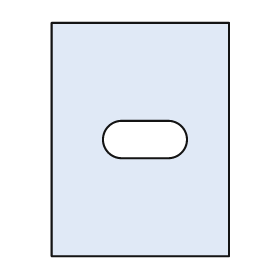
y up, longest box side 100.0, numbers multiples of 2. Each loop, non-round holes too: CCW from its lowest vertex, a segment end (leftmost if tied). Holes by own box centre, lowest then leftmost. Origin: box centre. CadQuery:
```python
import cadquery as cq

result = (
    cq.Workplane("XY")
    .moveTo(-38.0, -50.0)
    .lineTo(38.0, -50.0)
    .lineTo(38.0, 50.0)
    .lineTo(-38.0, 50.0)
    .close()
    .moveTo(-8.0, -8.0)
    .lineTo(12.0, -8.0)
    .threePointArc((20.0, 0.0), (12.0, 8.0))
    .lineTo(-8.0, 8.0)
    .threePointArc((-16.0, 0.0), (-8.0, -8.0))
    .close()
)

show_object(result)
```